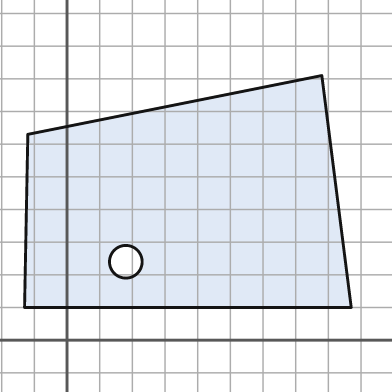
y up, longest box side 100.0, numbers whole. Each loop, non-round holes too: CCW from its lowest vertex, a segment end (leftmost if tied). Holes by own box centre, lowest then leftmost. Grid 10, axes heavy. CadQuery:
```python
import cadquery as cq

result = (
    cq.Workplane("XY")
    .moveTo(-13.0, 10.0)
    .lineTo(87.0, 10.0)
    .lineTo(78.0, 81.0)
    .lineTo(-12.0, 63.0)
    .close()
    .moveTo(18.0, 24.0)
    .circle(5.0)
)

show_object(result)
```